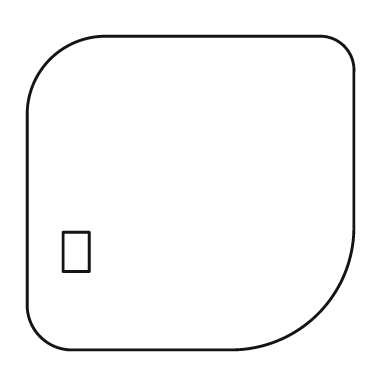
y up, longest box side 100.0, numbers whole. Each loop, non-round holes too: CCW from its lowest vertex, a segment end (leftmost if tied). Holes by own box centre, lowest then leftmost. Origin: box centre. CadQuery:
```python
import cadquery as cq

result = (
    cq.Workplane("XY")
    .moveTo(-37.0, -48.0)
    .lineTo(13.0, -48.0)
    .threePointArc((39.0, -37.0), (50.0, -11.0))
    .lineTo(50.0, 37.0)
    .threePointArc((47.0, 45.0), (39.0, 48.0))
    .lineTo(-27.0, 48.0)
    .threePointArc((-43.0, 41.0), (-50.0, 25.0))
    .lineTo(-50.0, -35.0)
    .threePointArc((-46.0, -44.0), (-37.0, -48.0))
    .close()
    .moveTo(-39.0, -24.0)
    .lineTo(-31.0, -24.0)
    .lineTo(-31.0, -12.0)
    .lineTo(-39.0, -12.0)
    .close()
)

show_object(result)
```